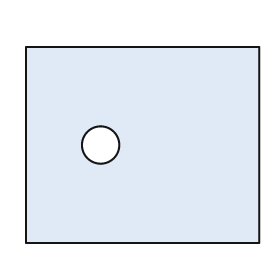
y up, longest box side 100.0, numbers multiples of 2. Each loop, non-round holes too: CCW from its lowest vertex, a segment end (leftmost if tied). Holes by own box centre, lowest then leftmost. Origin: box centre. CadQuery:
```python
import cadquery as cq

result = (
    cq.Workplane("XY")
    .moveTo(-50.0, -42.0)
    .lineTo(50.0, -42.0)
    .lineTo(50.0, 42.0)
    .lineTo(-50.0, 42.0)
    .close()
    .moveTo(-18.0, 0.0)
    .circle(8.0)
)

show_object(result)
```